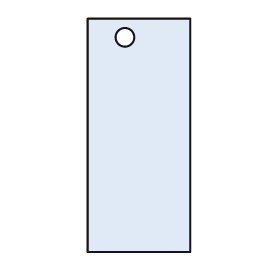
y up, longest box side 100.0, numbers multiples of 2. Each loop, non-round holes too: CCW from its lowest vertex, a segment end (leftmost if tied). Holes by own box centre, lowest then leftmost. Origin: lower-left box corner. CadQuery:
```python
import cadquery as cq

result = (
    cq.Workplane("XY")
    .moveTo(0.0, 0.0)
    .lineTo(44.0, 0.0)
    .lineTo(44.0, 100.0)
    .lineTo(0.0, 100.0)
    .close()
    .moveTo(16.0, 92.0)
    .circle(4.0)
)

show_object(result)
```